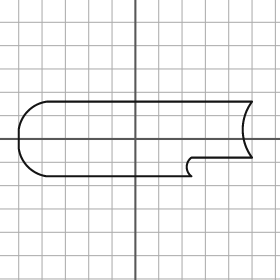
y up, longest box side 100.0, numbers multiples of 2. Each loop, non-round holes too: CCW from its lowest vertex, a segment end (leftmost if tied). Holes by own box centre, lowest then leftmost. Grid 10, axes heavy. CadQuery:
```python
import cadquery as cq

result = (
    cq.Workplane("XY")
    .moveTo(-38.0, -16.0)
    .lineTo(24.0, -16.0)
    .threePointArc((22.0, -12.0), (24.0, -8.0))
    .lineTo(50.0, -8.0)
    .threePointArc((46.0, 4.0), (50.0, 16.0))
    .lineTo(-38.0, 16.0)
    .threePointArc((-46.0, 12.0), (-50.0, 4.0))
    .lineTo(-50.0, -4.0)
    .threePointArc((-46.0, -12.0), (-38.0, -16.0))
    .close()
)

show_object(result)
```